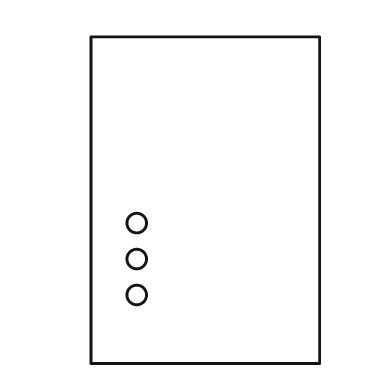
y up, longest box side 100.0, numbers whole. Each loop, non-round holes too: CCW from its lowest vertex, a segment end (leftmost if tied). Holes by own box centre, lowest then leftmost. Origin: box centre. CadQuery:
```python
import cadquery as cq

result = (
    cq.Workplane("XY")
    .moveTo(-35.0, -50.0)
    .lineTo(35.0, -50.0)
    .lineTo(35.0, 50.0)
    .lineTo(-35.0, 50.0)
    .close()
    .moveTo(-21.0, -29.0)
    .circle(3.0)
    .moveTo(-21.0, -18.0)
    .circle(3.0)
    .moveTo(-21.0, -7.0)
    .circle(3.0)
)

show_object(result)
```